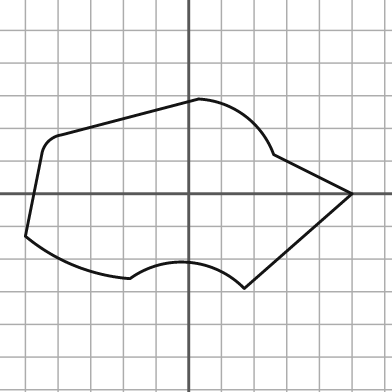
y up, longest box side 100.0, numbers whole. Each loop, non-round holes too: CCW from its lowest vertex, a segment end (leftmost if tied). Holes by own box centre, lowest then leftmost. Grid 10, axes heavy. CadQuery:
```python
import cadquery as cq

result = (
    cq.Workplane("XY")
    .moveTo(17.0, -29.0)
    .lineTo(50.0, 0.0)
    .lineTo(26.0, 12.0)
    .threePointArc((17.0, 24.0), (3.0, 29.0))
    .lineTo(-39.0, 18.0)
    .threePointArc((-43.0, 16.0), (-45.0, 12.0))
    .lineTo(-50.0, -13.0)
    .threePointArc((-35.0, -22.0), (-18.0, -26.0))
    .threePointArc((0.0, -21.0), (17.0, -29.0))
    .close()
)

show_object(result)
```